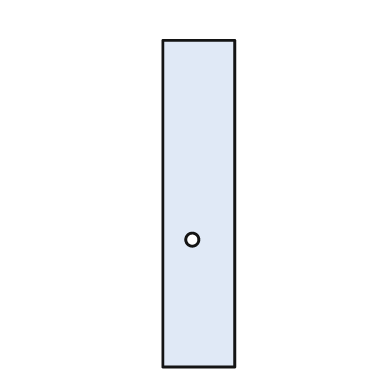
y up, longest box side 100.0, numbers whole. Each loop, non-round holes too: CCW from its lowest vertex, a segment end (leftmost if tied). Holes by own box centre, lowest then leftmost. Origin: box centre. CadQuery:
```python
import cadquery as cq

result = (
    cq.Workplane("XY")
    .moveTo(-11.0, -50.0)
    .lineTo(11.0, -50.0)
    .lineTo(11.0, 50.0)
    .lineTo(-11.0, 50.0)
    .close()
    .moveTo(-2.0, -11.0)
    .circle(2.0)
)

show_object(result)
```